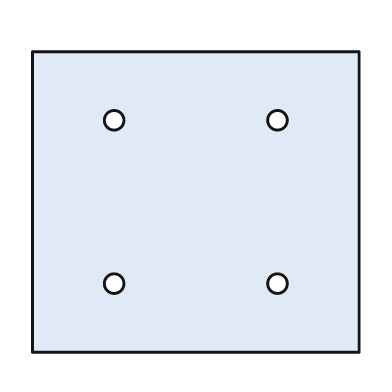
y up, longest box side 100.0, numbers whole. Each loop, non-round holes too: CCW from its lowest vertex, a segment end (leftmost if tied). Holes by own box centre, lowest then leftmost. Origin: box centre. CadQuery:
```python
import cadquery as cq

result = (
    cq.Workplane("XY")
    .moveTo(-50.0, -46.0)
    .lineTo(50.0, -46.0)
    .lineTo(50.0, 46.0)
    .lineTo(-50.0, 46.0)
    .close()
    .moveTo(-25.0, -25.0)
    .circle(3.0)
    .moveTo(25.0, -25.0)
    .circle(3.0)
    .moveTo(-25.0, 25.0)
    .circle(3.0)
    .moveTo(25.0, 25.0)
    .circle(3.0)
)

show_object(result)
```